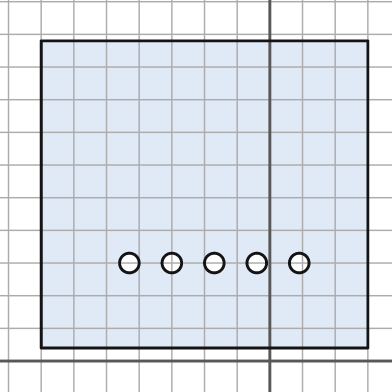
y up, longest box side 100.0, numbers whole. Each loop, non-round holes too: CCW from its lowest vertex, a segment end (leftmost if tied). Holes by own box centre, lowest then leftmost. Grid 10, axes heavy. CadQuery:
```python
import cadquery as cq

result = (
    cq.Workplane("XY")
    .moveTo(-70.0, 4.0)
    .lineTo(30.0, 4.0)
    .lineTo(30.0, 98.0)
    .lineTo(-70.0, 98.0)
    .close()
    .moveTo(-43.0, 30.0)
    .circle(3.0)
    .moveTo(-30.0, 30.0)
    .circle(3.0)
    .moveTo(-17.0, 30.0)
    .circle(3.0)
    .moveTo(-4.0, 30.0)
    .circle(3.0)
    .moveTo(9.0, 30.0)
    .circle(3.0)
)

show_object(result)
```